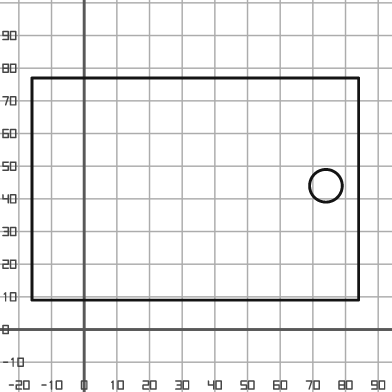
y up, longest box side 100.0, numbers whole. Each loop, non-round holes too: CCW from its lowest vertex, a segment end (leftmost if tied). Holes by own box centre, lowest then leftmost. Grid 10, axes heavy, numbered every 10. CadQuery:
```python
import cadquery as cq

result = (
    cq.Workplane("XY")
    .moveTo(-16.0, 9.0)
    .lineTo(84.0, 9.0)
    .lineTo(84.0, 77.0)
    .lineTo(-16.0, 77.0)
    .close()
    .moveTo(74.0, 44.0)
    .circle(5.0)
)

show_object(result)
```